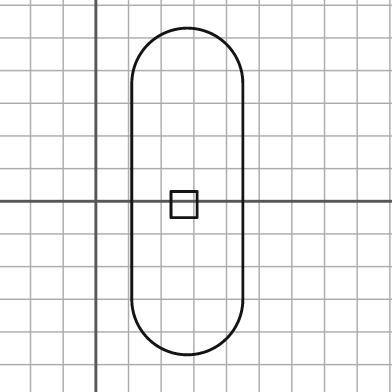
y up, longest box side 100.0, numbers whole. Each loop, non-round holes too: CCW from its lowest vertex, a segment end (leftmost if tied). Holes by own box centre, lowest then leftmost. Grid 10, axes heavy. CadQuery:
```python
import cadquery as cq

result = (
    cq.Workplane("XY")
    .moveTo(11.0, -30.0)
    .threePointArc((28.0, -47.0), (45.0, -30.0))
    .lineTo(45.0, 36.0)
    .threePointArc((28.0, 53.0), (11.0, 36.0))
    .close()
    .moveTo(23.0, -5.0)
    .lineTo(31.0, -5.0)
    .lineTo(31.0, 3.0)
    .lineTo(23.0, 3.0)
    .close()
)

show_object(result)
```